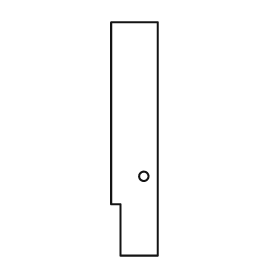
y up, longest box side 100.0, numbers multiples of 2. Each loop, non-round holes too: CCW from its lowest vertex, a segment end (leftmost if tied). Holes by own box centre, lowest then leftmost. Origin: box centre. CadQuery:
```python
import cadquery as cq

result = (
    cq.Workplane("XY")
    .moveTo(-6.0, -50.0)
    .lineTo(10.0, -50.0)
    .lineTo(10.0, 50.0)
    .lineTo(-10.0, 50.0)
    .lineTo(-10.0, -28.0)
    .lineTo(-6.0, -28.0)
    .close()
    .moveTo(4.0, -16.0)
    .circle(2.0)
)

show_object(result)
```